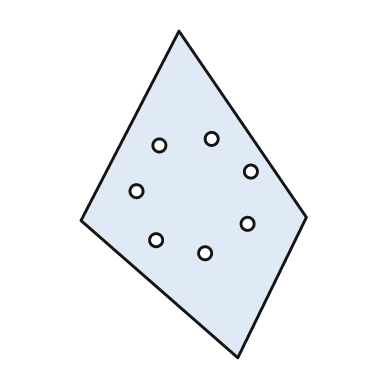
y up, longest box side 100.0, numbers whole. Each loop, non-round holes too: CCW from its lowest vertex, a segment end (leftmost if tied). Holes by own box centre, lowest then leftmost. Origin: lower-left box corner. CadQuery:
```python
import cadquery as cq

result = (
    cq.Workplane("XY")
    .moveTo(48.0, 0.0)
    .lineTo(69.0, 43.0)
    .lineTo(30.0, 100.0)
    .lineTo(0.0, 42.0)
    .close()
    .moveTo(38.0, 32.0)
    .circle(2.0)
    .moveTo(23.0, 36.0)
    .circle(2.0)
    .moveTo(51.0, 41.0)
    .circle(2.0)
    .moveTo(17.0, 51.0)
    .circle(2.0)
    .moveTo(52.0, 57.0)
    .circle(2.0)
    .moveTo(24.0, 65.0)
    .circle(2.0)
    .moveTo(40.0, 67.0)
    .circle(2.0)
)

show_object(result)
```